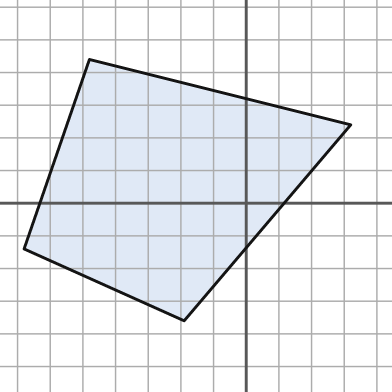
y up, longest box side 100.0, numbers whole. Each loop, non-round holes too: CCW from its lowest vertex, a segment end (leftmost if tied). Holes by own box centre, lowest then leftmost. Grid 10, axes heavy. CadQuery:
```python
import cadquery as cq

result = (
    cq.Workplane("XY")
    .moveTo(-19.0, -36.0)
    .lineTo(32.0, 24.0)
    .lineTo(-48.0, 44.0)
    .lineTo(-68.0, -14.0)
    .close()
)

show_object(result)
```